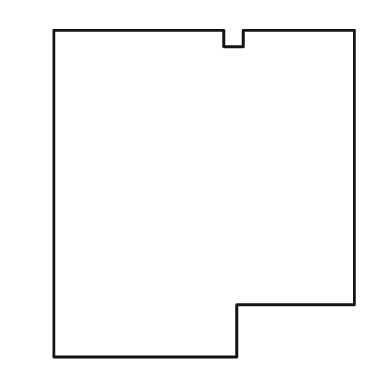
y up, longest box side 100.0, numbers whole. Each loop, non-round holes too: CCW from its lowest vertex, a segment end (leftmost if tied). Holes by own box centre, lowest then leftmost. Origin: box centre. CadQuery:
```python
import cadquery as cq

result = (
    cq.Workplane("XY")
    .moveTo(-46.0, -50.0)
    .lineTo(10.0, -50.0)
    .lineTo(10.0, -34.0)
    .lineTo(46.0, -34.0)
    .lineTo(46.0, 50.0)
    .lineTo(12.0, 50.0)
    .lineTo(12.0, 45.0)
    .lineTo(6.0, 45.0)
    .lineTo(6.0, 50.0)
    .lineTo(-46.0, 50.0)
    .close()
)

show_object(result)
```